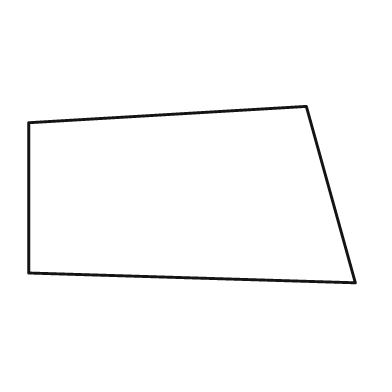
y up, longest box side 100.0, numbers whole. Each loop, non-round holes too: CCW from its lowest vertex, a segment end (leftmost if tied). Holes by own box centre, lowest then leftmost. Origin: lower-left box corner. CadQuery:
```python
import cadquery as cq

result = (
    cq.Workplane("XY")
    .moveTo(100.0, 0.0)
    .lineTo(85.0, 54.0)
    .lineTo(0.0, 49.0)
    .lineTo(0.0, 3.0)
    .close()
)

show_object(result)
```